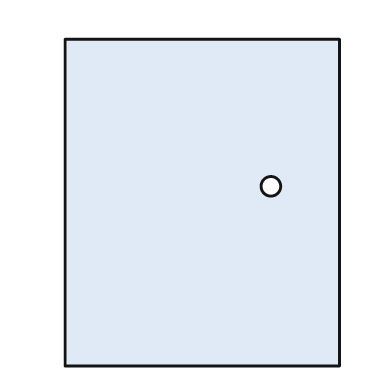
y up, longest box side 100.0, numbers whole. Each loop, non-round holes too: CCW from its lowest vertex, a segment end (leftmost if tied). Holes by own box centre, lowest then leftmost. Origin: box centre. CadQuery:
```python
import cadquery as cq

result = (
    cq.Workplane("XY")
    .moveTo(-42.0, -50.0)
    .lineTo(42.0, -50.0)
    .lineTo(42.0, 50.0)
    .lineTo(-42.0, 50.0)
    .close()
    .moveTo(21.0, 5.0)
    .circle(3.0)
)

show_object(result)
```